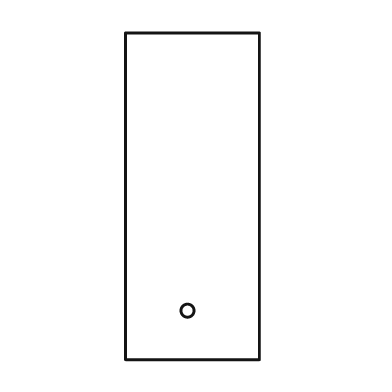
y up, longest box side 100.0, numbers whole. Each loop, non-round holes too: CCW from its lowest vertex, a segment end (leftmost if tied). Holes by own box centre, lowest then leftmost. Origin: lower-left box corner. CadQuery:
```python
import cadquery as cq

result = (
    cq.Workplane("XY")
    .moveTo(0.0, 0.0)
    .lineTo(41.0, 0.0)
    .lineTo(41.0, 100.0)
    .lineTo(0.0, 100.0)
    .close()
    .moveTo(19.0, 15.0)
    .circle(2.0)
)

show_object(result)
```